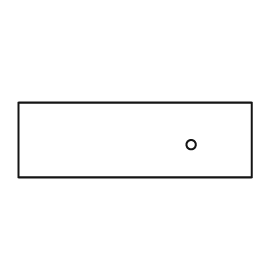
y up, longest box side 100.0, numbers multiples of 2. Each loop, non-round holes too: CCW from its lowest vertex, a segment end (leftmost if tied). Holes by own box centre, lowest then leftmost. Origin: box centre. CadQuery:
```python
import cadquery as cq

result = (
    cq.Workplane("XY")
    .moveTo(-50.0, -16.0)
    .lineTo(50.0, -16.0)
    .lineTo(50.0, 16.0)
    .lineTo(-50.0, 16.0)
    .close()
    .moveTo(24.0, -2.0)
    .circle(2.0)
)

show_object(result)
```